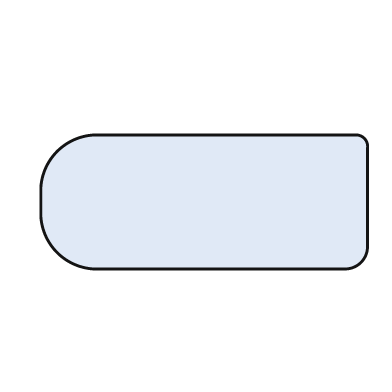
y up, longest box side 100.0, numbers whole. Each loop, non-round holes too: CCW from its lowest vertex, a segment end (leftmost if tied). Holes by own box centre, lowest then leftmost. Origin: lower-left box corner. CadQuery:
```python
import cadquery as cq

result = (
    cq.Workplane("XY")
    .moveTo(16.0, 0.0)
    .lineTo(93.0, 0.0)
    .threePointArc((98.0, 2.0), (100.0, 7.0))
    .lineTo(100.0, 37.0)
    .threePointArc((99.0, 40.0), (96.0, 41.0))
    .lineTo(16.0, 41.0)
    .threePointArc((5.0, 36.0), (0.0, 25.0))
    .lineTo(0.0, 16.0)
    .threePointArc((5.0, 5.0), (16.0, 0.0))
    .close()
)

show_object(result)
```